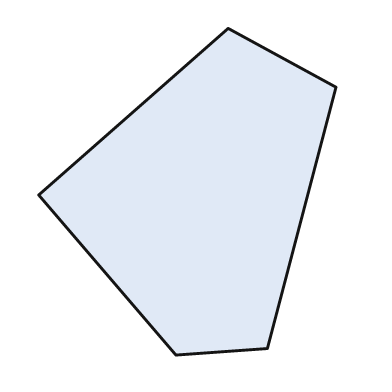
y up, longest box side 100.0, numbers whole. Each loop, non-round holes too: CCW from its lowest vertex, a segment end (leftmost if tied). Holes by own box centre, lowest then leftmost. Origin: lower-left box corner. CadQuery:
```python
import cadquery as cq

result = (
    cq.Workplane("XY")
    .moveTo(42.0, 0.0)
    .lineTo(70.0, 2.0)
    .lineTo(91.0, 82.0)
    .lineTo(58.0, 100.0)
    .lineTo(0.0, 49.0)
    .close()
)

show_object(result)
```